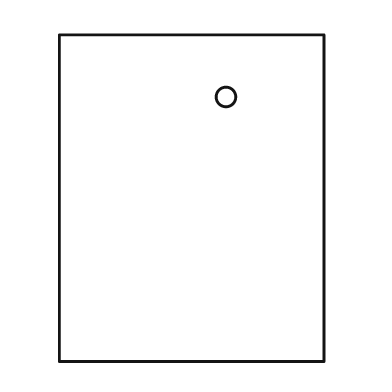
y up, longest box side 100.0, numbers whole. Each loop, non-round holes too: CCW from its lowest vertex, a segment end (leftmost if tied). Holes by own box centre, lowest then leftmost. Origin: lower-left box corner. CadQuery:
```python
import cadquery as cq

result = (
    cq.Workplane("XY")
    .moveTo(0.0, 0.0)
    .lineTo(81.0, 0.0)
    .lineTo(81.0, 100.0)
    .lineTo(0.0, 100.0)
    .close()
    .moveTo(51.0, 81.0)
    .circle(3.0)
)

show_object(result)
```